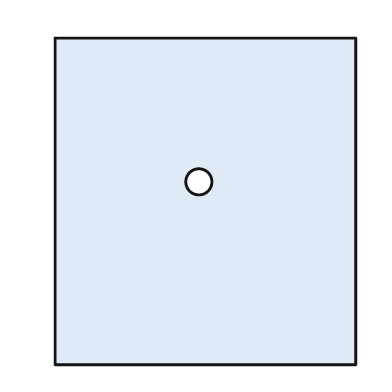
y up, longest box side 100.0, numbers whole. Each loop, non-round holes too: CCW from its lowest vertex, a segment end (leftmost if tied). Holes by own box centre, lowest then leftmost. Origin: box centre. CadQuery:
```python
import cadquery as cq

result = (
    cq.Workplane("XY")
    .moveTo(-46.0, -50.0)
    .lineTo(46.0, -50.0)
    .lineTo(46.0, 50.0)
    .lineTo(-46.0, 50.0)
    .close()
    .moveTo(-2.0, 6.0)
    .circle(4.0)
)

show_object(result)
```